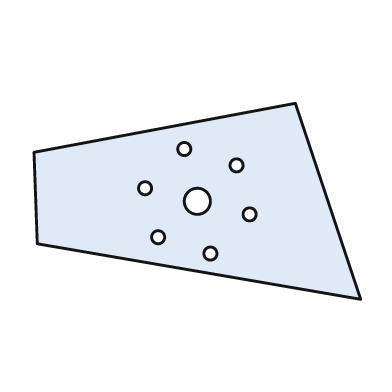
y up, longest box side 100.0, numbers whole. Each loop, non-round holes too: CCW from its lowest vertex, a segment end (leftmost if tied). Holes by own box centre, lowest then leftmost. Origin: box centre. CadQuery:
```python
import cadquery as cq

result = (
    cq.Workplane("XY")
    .moveTo(50.0, -30.0)
    .lineTo(30.0, 30.0)
    .lineTo(-50.0, 15.0)
    .lineTo(-49.0, -13.0)
    .close()
    .moveTo(4.0, -16.0)
    .circle(2.0)
    .moveTo(-12.0, -11.0)
    .circle(2.0)
    .moveTo(16.0, -4.0)
    .circle(2.0)
    .moveTo(0.0, 0.0)
    .circle(4.0)
    .moveTo(-16.0, 4.0)
    .circle(2.0)
    .moveTo(12.0, 11.0)
    .circle(2.0)
    .moveTo(-4.0, 16.0)
    .circle(2.0)
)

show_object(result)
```